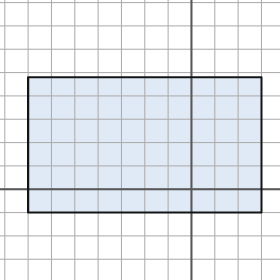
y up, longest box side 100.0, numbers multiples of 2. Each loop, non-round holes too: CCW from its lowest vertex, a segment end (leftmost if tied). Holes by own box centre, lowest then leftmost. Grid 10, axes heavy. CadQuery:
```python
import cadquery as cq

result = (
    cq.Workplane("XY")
    .moveTo(-70.0, -10.0)
    .lineTo(30.0, -10.0)
    .lineTo(30.0, 48.0)
    .lineTo(-70.0, 48.0)
    .close()
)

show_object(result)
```